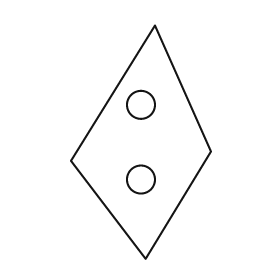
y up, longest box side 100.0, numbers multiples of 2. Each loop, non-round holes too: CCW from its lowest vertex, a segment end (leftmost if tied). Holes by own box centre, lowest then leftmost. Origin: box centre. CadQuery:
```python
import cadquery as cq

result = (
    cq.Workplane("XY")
    .moveTo(2.0, -50.0)
    .lineTo(30.0, -4.0)
    .lineTo(6.0, 50.0)
    .lineTo(-30.0, -8.0)
    .close()
    .moveTo(0.0, -16.0)
    .circle(6.0)
    .moveTo(0.0, 16.0)
    .circle(6.0)
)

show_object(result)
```